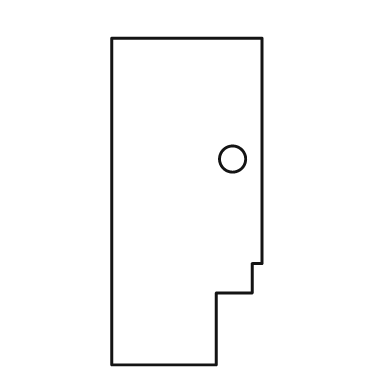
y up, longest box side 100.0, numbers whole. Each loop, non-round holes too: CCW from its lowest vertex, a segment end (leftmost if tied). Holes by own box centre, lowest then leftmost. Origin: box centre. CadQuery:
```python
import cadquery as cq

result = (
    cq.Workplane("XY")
    .moveTo(-23.0, -50.0)
    .lineTo(9.0, -50.0)
    .lineTo(9.0, -28.0)
    .lineTo(20.0, -28.0)
    .lineTo(20.0, -19.0)
    .lineTo(23.0, -19.0)
    .lineTo(23.0, 50.0)
    .lineTo(-23.0, 50.0)
    .close()
    .moveTo(14.0, 13.0)
    .circle(4.0)
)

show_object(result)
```